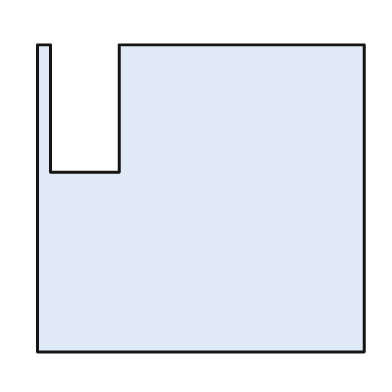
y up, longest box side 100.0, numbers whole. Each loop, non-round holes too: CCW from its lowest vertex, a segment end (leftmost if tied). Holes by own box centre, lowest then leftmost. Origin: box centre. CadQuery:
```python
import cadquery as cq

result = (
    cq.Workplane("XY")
    .moveTo(-50.0, -47.0)
    .lineTo(50.0, -47.0)
    .lineTo(50.0, 47.0)
    .lineTo(-25.0, 47.0)
    .lineTo(-25.0, 8.0)
    .lineTo(-46.0, 8.0)
    .lineTo(-46.0, 47.0)
    .lineTo(-50.0, 47.0)
    .close()
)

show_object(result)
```